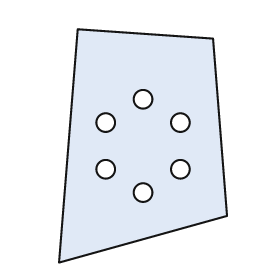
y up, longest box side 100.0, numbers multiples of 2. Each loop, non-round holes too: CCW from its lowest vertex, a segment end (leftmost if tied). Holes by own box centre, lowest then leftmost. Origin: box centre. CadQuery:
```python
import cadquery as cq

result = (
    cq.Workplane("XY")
    .moveTo(-36.0, -50.0)
    .lineTo(36.0, -30.0)
    .lineTo(30.0, 46.0)
    .lineTo(-28.0, 50.0)
    .close()
    .moveTo(0.0, -20.0)
    .circle(4.0)
    .moveTo(-16.0, -10.0)
    .circle(4.0)
    .moveTo(16.0, -10.0)
    .circle(4.0)
    .moveTo(-16.0, 10.0)
    .circle(4.0)
    .moveTo(16.0, 10.0)
    .circle(4.0)
    .moveTo(0.0, 20.0)
    .circle(4.0)
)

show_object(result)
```